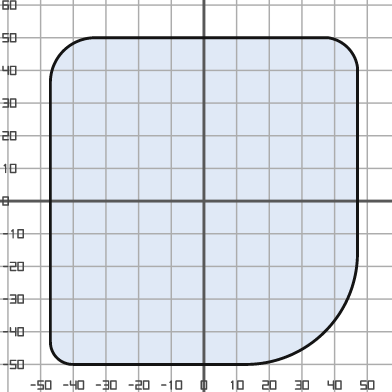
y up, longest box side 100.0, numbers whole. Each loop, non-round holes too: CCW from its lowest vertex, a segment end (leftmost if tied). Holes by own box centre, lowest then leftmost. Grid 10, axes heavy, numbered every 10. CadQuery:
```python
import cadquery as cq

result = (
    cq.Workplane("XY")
    .moveTo(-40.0, -50.0)
    .lineTo(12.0, -50.0)
    .threePointArc((37.0, -40.0), (47.0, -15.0))
    .lineTo(47.0, 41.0)
    .threePointArc((44.0, 47.0), (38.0, 50.0))
    .lineTo(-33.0, 50.0)
    .threePointArc((-43.0, 46.0), (-47.0, 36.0))
    .lineTo(-47.0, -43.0)
    .threePointArc((-45.0, -48.0), (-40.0, -50.0))
    .close()
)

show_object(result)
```